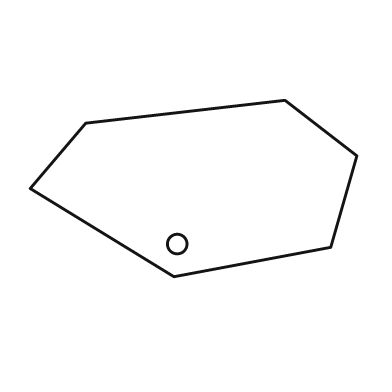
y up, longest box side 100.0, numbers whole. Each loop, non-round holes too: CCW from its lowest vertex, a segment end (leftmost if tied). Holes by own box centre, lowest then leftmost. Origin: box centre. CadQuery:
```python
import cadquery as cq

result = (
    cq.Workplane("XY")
    .moveTo(-6.0, -27.0)
    .lineTo(42.0, -18.0)
    .lineTo(50.0, 10.0)
    .lineTo(28.0, 27.0)
    .lineTo(-33.0, 20.0)
    .lineTo(-50.0, 0.0)
    .close()
    .moveTo(-5.0, -17.0)
    .circle(3.0)
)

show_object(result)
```